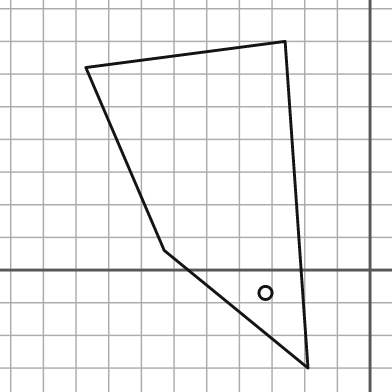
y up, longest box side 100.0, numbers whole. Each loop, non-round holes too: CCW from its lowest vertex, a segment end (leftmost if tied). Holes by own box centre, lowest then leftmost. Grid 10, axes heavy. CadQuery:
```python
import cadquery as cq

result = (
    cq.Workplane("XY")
    .moveTo(-19.0, -30.0)
    .lineTo(-26.0, 70.0)
    .lineTo(-87.0, 62.0)
    .lineTo(-63.0, 6.0)
    .close()
    .moveTo(-32.0, -7.0)
    .circle(2.0)
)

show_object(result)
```